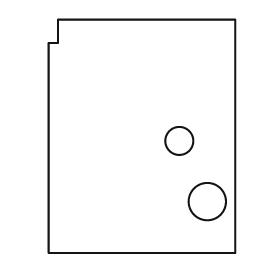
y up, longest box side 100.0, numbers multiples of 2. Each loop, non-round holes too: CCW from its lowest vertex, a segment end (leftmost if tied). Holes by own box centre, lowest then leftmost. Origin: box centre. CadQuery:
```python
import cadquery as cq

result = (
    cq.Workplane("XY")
    .moveTo(-40.0, -50.0)
    .lineTo(40.0, -50.0)
    .lineTo(40.0, 50.0)
    .lineTo(-36.0, 50.0)
    .lineTo(-36.0, 40.0)
    .lineTo(-40.0, 40.0)
    .close()
    .moveTo(28.0, -28.0)
    .circle(8.0)
    .moveTo(16.0, -2.0)
    .circle(6.0)
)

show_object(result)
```